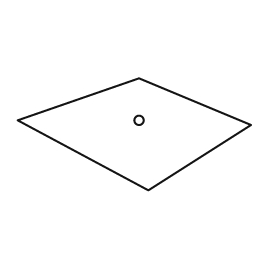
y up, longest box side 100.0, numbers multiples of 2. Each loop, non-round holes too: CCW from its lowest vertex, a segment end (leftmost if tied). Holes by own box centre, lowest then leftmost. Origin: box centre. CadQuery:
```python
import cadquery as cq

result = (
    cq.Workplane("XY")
    .moveTo(6.0, -24.0)
    .lineTo(50.0, 4.0)
    .lineTo(2.0, 24.0)
    .lineTo(-50.0, 6.0)
    .close()
    .moveTo(2.0, 6.0)
    .circle(2.0)
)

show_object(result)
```